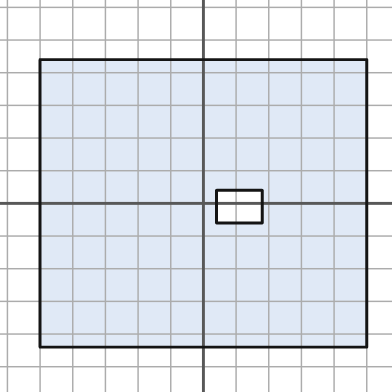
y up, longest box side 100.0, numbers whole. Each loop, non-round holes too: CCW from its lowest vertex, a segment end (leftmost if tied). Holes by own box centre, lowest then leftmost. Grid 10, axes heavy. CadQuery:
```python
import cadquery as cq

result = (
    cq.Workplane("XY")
    .moveTo(-50.0, -44.0)
    .lineTo(50.0, -44.0)
    .lineTo(50.0, 44.0)
    .lineTo(-50.0, 44.0)
    .close()
    .moveTo(4.0, -6.0)
    .lineTo(18.0, -6.0)
    .lineTo(18.0, 4.0)
    .lineTo(4.0, 4.0)
    .close()
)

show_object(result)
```